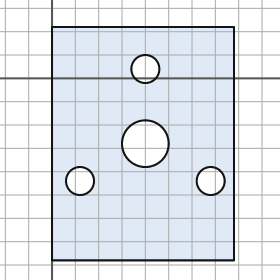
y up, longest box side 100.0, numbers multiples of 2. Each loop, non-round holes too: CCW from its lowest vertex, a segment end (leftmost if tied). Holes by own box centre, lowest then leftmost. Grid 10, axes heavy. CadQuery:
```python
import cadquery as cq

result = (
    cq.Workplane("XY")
    .moveTo(0.0, -78.0)
    .lineTo(78.0, -78.0)
    .lineTo(78.0, 22.0)
    .lineTo(0.0, 22.0)
    .close()
    .moveTo(12.0, -44.0)
    .circle(6.0)
    .moveTo(68.0, -44.0)
    .circle(6.0)
    .moveTo(40.0, -28.0)
    .circle(10.0)
    .moveTo(40.0, 4.0)
    .circle(6.0)
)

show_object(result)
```